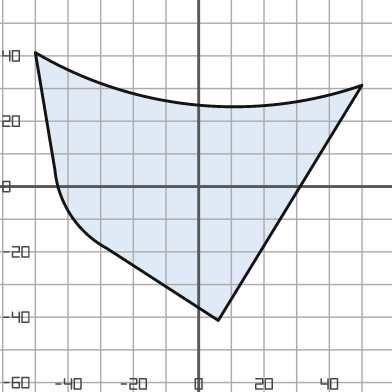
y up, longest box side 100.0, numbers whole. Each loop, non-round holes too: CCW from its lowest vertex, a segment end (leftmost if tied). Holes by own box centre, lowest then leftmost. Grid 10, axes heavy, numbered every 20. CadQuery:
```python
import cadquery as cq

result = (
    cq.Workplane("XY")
    .moveTo(6.0, -41.0)
    .lineTo(50.0, 31.0)
    .threePointArc((-1.0, 25.0), (-50.0, 41.0))
    .lineTo(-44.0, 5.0)
    .threePointArc((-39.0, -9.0), (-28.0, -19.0))
    .close()
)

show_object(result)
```